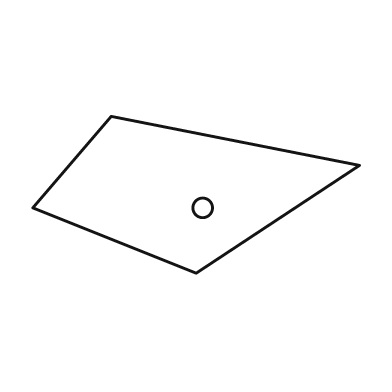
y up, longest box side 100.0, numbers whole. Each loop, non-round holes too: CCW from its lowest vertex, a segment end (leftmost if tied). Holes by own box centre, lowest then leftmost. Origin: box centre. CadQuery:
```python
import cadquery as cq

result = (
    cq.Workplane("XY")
    .moveTo(0.0, -24.0)
    .lineTo(50.0, 9.0)
    .lineTo(-26.0, 24.0)
    .lineTo(-50.0, -4.0)
    .close()
    .moveTo(2.0, -4.0)
    .circle(3.0)
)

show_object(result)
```